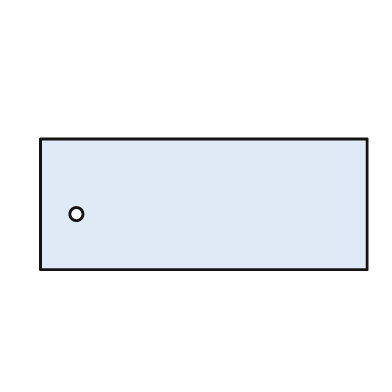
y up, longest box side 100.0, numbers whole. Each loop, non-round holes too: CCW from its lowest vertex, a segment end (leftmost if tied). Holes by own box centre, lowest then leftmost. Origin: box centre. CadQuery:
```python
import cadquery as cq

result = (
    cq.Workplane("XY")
    .moveTo(-50.0, -20.0)
    .lineTo(50.0, -20.0)
    .lineTo(50.0, 20.0)
    .lineTo(-50.0, 20.0)
    .close()
    .moveTo(-39.0, -3.0)
    .circle(2.0)
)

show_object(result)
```